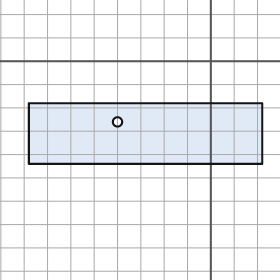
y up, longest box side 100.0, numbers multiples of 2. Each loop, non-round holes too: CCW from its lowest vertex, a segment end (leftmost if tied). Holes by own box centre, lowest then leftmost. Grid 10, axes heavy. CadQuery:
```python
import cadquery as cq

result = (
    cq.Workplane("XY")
    .moveTo(-78.0, -44.0)
    .lineTo(22.0, -44.0)
    .lineTo(22.0, -18.0)
    .lineTo(-78.0, -18.0)
    .close()
    .moveTo(-40.0, -26.0)
    .circle(2.0)
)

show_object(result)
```